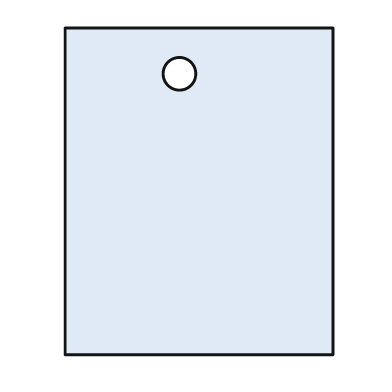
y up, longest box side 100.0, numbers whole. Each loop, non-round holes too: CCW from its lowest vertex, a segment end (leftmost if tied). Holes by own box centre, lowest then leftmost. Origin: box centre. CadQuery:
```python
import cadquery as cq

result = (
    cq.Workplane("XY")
    .moveTo(-41.0, -50.0)
    .lineTo(41.0, -50.0)
    .lineTo(41.0, 50.0)
    .lineTo(-41.0, 50.0)
    .close()
    .moveTo(-6.0, 36.0)
    .circle(5.0)
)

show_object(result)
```